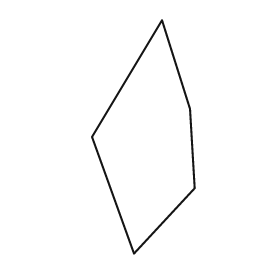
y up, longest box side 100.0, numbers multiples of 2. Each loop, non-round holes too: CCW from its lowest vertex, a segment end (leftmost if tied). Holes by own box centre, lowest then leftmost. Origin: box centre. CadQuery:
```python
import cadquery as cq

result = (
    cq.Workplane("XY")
    .moveTo(-4.0, -50.0)
    .lineTo(22.0, -22.0)
    .lineTo(20.0, 12.0)
    .lineTo(8.0, 50.0)
    .lineTo(-22.0, 0.0)
    .close()
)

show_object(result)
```